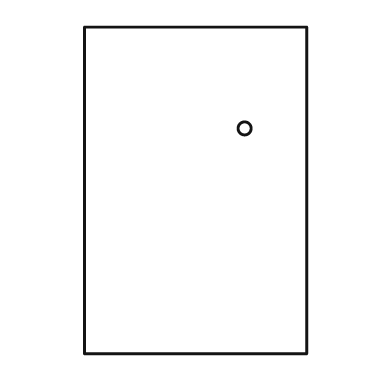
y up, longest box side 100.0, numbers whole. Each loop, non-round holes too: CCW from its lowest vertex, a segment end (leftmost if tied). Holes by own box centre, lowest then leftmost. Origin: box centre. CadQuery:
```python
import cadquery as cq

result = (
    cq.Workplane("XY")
    .moveTo(-34.0, -50.0)
    .lineTo(34.0, -50.0)
    .lineTo(34.0, 50.0)
    .lineTo(-34.0, 50.0)
    .close()
    .moveTo(15.0, 19.0)
    .circle(2.0)
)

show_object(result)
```